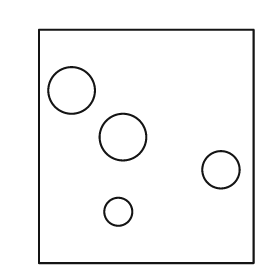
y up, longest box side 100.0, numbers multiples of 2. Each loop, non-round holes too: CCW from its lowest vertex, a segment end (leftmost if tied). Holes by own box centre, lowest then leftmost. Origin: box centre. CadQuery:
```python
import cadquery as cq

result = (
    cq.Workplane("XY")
    .moveTo(-46.0, -50.0)
    .lineTo(46.0, -50.0)
    .lineTo(46.0, 50.0)
    .lineTo(-46.0, 50.0)
    .close()
    .moveTo(-12.0, -28.0)
    .circle(6.0)
    .moveTo(32.0, -10.0)
    .circle(8.0)
    .moveTo(-10.0, 4.0)
    .circle(10.0)
    .moveTo(-32.0, 24.0)
    .circle(10.0)
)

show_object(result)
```